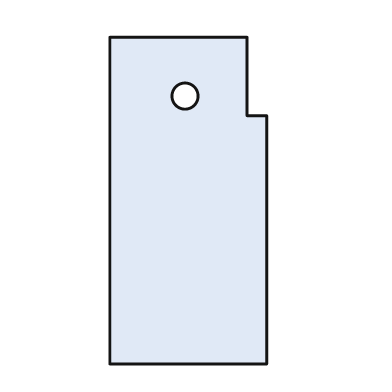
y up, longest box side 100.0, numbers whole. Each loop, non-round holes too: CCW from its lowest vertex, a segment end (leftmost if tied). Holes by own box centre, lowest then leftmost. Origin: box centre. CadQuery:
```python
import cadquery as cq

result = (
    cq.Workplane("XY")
    .moveTo(-24.0, -50.0)
    .lineTo(24.0, -50.0)
    .lineTo(24.0, 26.0)
    .lineTo(18.0, 26.0)
    .lineTo(18.0, 50.0)
    .lineTo(-24.0, 50.0)
    .close()
    .moveTo(-1.0, 32.0)
    .circle(4.0)
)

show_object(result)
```